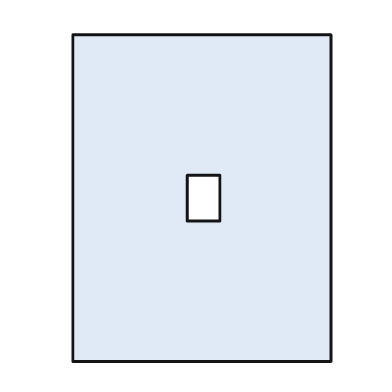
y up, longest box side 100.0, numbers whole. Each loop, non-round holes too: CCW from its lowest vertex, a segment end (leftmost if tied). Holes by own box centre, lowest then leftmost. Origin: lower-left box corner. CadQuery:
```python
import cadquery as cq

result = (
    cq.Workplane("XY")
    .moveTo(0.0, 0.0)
    .lineTo(79.0, 0.0)
    .lineTo(79.0, 100.0)
    .lineTo(0.0, 100.0)
    .close()
    .moveTo(35.0, 43.0)
    .lineTo(45.0, 43.0)
    .lineTo(45.0, 57.0)
    .lineTo(35.0, 57.0)
    .close()
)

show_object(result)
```